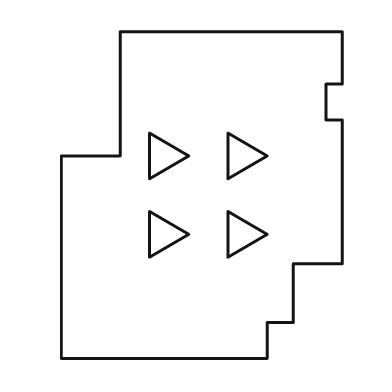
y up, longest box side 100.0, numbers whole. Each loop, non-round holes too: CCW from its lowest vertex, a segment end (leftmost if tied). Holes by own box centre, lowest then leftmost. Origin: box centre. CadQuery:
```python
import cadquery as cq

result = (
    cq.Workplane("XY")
    .moveTo(-43.0, -50.0)
    .lineTo(20.0, -50.0)
    .lineTo(20.0, -39.0)
    .lineTo(28.0, -39.0)
    .lineTo(28.0, -21.0)
    .lineTo(43.0, -21.0)
    .lineTo(43.0, 23.0)
    .lineTo(38.0, 23.0)
    .lineTo(38.0, 34.0)
    .lineTo(43.0, 34.0)
    .lineTo(43.0, 50.0)
    .lineTo(-25.0, 50.0)
    .lineTo(-25.0, 12.0)
    .lineTo(-43.0, 12.0)
    .close()
    .moveTo(-16.0, -19.0)
    .lineTo(-4.0, -12.0)
    .lineTo(-16.0, -5.0)
    .close()
    .moveTo(8.0, -19.0)
    .lineTo(20.0, -12.0)
    .lineTo(8.0, -5.0)
    .close()
    .moveTo(-16.0, 5.0)
    .lineTo(-4.0, 12.0)
    .lineTo(-16.0, 19.0)
    .close()
    .moveTo(8.0, 5.0)
    .lineTo(20.0, 12.0)
    .lineTo(8.0, 19.0)
    .close()
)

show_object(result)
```